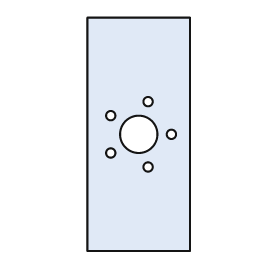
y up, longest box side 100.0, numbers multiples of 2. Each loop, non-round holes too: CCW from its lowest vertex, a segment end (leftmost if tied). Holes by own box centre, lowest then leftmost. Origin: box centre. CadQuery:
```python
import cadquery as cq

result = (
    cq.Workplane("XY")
    .moveTo(-22.0, -50.0)
    .lineTo(22.0, -50.0)
    .lineTo(22.0, 50.0)
    .lineTo(-22.0, 50.0)
    .close()
    .moveTo(4.0, -14.0)
    .circle(2.0)
    .moveTo(-12.0, -8.0)
    .circle(2.0)
    .moveTo(0.0, 0.0)
    .circle(8.0)
    .moveTo(14.0, 0.0)
    .circle(2.0)
    .moveTo(-12.0, 8.0)
    .circle(2.0)
    .moveTo(4.0, 14.0)
    .circle(2.0)
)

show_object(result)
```